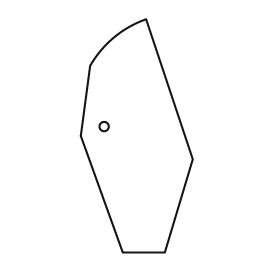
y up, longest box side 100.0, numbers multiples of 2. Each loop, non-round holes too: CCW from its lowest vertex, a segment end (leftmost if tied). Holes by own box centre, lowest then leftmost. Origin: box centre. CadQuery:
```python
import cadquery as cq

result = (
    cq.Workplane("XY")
    .moveTo(-6.0, -50.0)
    .lineTo(12.0, -50.0)
    .lineTo(24.0, -10.0)
    .lineTo(4.0, 50.0)
    .threePointArc((-10.0, 42.0), (-20.0, 30.0))
    .lineTo(-24.0, 0.0)
    .close()
    .moveTo(-14.0, 4.0)
    .circle(2.0)
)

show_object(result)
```